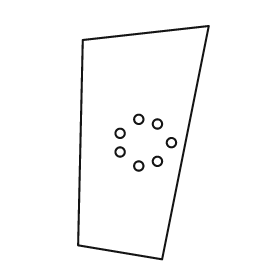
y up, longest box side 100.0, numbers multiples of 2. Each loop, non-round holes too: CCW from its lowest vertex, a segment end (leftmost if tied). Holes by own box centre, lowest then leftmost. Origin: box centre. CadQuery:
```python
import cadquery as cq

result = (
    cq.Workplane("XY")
    .moveTo(8.0, -50.0)
    .lineTo(28.0, 50.0)
    .lineTo(-26.0, 44.0)
    .lineTo(-28.0, -44.0)
    .close()
    .moveTo(-2.0, -10.0)
    .circle(2.0)
    .moveTo(6.0, -8.0)
    .circle(2.0)
    .moveTo(-10.0, -4.0)
    .circle(2.0)
    .moveTo(12.0, 0.0)
    .circle(2.0)
    .moveTo(-10.0, 4.0)
    .circle(2.0)
    .moveTo(6.0, 8.0)
    .circle(2.0)
    .moveTo(-2.0, 10.0)
    .circle(2.0)
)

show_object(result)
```